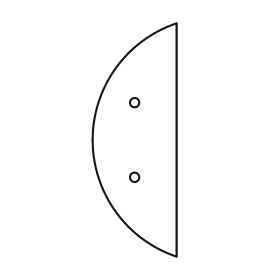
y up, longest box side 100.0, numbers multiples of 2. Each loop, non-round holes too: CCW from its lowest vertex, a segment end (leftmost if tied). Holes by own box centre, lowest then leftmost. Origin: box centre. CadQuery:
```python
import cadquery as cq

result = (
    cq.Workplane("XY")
    .moveTo(18.0, -50.0)
    .lineTo(18.0, 50.0)
    .threePointArc((-18.0, 0.0), (18.0, -50.0))
    .close()
    .moveTo(0.0, -16.0)
    .circle(2.0)
    .moveTo(0.0, 16.0)
    .circle(2.0)
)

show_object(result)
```